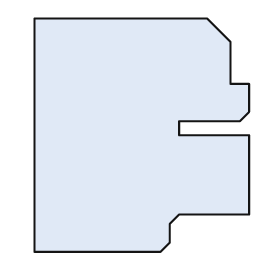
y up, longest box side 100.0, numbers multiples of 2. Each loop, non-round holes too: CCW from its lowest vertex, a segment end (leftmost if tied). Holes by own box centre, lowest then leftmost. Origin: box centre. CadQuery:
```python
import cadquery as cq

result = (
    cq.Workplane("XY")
    .moveTo(-46.0, -50.0)
    .lineTo(8.0, -50.0)
    .lineTo(12.0, -46.0)
    .lineTo(12.0, -38.0)
    .lineTo(16.0, -34.0)
    .lineTo(46.0, -34.0)
    .lineTo(46.0, 0.0)
    .lineTo(16.0, 0.0)
    .lineTo(16.0, 6.0)
    .lineTo(42.0, 6.0)
    .lineTo(46.0, 10.0)
    .lineTo(46.0, 22.0)
    .lineTo(38.0, 22.0)
    .lineTo(38.0, 40.0)
    .lineTo(28.0, 50.0)
    .lineTo(-46.0, 50.0)
    .close()
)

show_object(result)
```